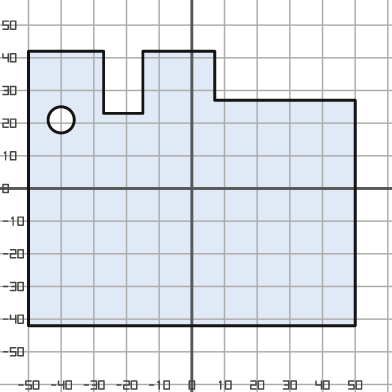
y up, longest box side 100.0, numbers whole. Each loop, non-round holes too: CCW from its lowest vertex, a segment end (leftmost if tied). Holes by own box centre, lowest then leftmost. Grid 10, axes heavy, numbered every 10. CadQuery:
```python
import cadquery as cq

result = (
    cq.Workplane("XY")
    .moveTo(-50.0, -42.0)
    .lineTo(50.0, -42.0)
    .lineTo(50.0, 27.0)
    .lineTo(7.0, 27.0)
    .lineTo(7.0, 42.0)
    .lineTo(-15.0, 42.0)
    .lineTo(-15.0, 23.0)
    .lineTo(-27.0, 23.0)
    .lineTo(-27.0, 42.0)
    .lineTo(-50.0, 42.0)
    .close()
    .moveTo(-40.0, 21.0)
    .circle(4.0)
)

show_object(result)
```